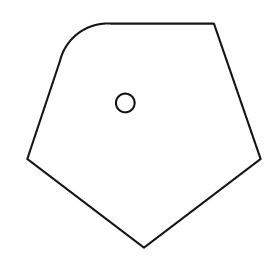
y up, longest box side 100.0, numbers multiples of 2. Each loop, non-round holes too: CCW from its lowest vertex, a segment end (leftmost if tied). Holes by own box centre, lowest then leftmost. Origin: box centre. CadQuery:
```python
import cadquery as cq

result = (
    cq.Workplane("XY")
    .moveTo(0.0, -48.0)
    .lineTo(50.0, -10.0)
    .lineTo(30.0, 48.0)
    .lineTo(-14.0, 48.0)
    .threePointArc((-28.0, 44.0), (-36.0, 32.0))
    .lineTo(-50.0, -10.0)
    .close()
    .moveTo(-8.0, 14.0)
    .circle(4.0)
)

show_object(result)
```